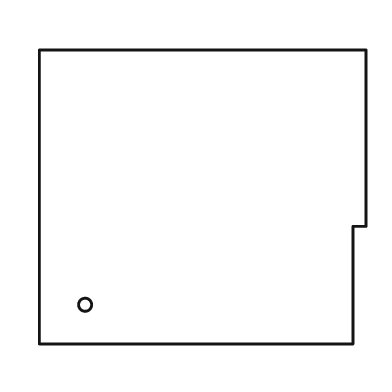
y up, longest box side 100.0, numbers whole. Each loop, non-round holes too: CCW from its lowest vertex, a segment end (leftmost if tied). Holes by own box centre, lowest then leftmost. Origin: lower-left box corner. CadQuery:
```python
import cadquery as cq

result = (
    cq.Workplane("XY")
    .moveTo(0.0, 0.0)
    .lineTo(96.0, 0.0)
    .lineTo(96.0, 36.0)
    .lineTo(100.0, 36.0)
    .lineTo(100.0, 90.0)
    .lineTo(0.0, 90.0)
    .close()
    .moveTo(14.0, 12.0)
    .circle(2.0)
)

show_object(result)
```